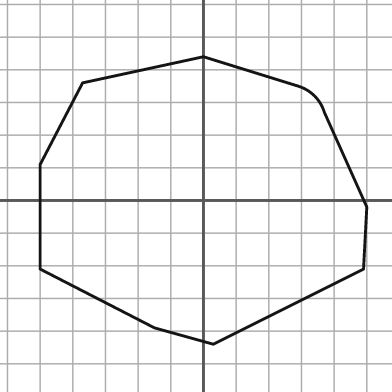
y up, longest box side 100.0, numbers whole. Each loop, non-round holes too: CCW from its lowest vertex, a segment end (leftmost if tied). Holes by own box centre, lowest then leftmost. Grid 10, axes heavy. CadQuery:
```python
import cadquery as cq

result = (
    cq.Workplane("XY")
    .moveTo(3.0, -44.0)
    .lineTo(49.0, -21.0)
    .lineTo(50.0, -2.0)
    .lineTo(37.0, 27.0)
    .threePointArc((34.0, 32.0), (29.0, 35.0))
    .lineTo(0.0, 44.0)
    .lineTo(-37.0, 36.0)
    .lineTo(-50.0, 11.0)
    .lineTo(-50.0, -21.0)
    .lineTo(-15.0, -39.0)
    .close()
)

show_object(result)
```